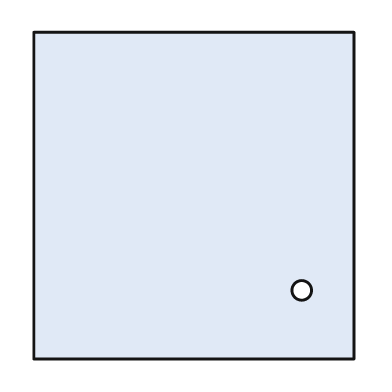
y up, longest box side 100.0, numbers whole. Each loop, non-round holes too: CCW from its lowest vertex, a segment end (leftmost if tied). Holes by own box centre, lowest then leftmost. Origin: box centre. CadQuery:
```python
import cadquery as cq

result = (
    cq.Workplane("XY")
    .moveTo(-49.0, -50.0)
    .lineTo(49.0, -50.0)
    .lineTo(49.0, 50.0)
    .lineTo(-49.0, 50.0)
    .close()
    .moveTo(33.0, -29.0)
    .circle(3.0)
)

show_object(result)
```